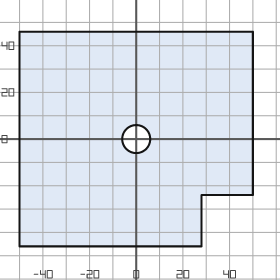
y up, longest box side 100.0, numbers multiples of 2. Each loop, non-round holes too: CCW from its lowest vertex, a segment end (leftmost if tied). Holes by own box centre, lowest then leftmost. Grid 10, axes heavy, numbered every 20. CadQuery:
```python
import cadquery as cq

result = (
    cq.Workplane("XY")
    .moveTo(-50.0, -46.0)
    .lineTo(28.0, -46.0)
    .lineTo(28.0, -24.0)
    .lineTo(50.0, -24.0)
    .lineTo(50.0, 46.0)
    .lineTo(-50.0, 46.0)
    .close()
    .moveTo(0.0, 0.0)
    .circle(6.0)
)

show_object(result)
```